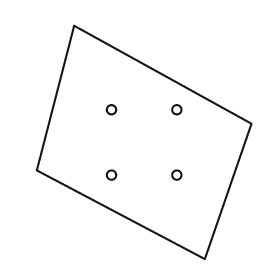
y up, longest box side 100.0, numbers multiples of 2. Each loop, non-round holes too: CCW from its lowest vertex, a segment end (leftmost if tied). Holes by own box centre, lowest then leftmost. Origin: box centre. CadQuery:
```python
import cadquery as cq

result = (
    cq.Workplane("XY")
    .moveTo(26.0, -50.0)
    .lineTo(46.0, 8.0)
    .lineTo(-30.0, 50.0)
    .lineTo(-46.0, -12.0)
    .close()
    .moveTo(-14.0, -14.0)
    .circle(2.0)
    .moveTo(14.0, -14.0)
    .circle(2.0)
    .moveTo(-14.0, 14.0)
    .circle(2.0)
    .moveTo(14.0, 14.0)
    .circle(2.0)
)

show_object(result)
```